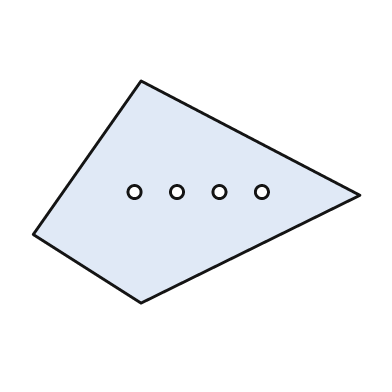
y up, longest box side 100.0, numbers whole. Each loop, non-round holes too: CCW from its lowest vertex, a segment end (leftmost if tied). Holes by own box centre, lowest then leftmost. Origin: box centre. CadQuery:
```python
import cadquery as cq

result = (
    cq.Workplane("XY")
    .moveTo(-17.0, -34.0)
    .lineTo(50.0, -1.0)
    .lineTo(-17.0, 34.0)
    .lineTo(-50.0, -13.0)
    .close()
    .moveTo(-19.0, 0.0)
    .circle(2.0)
    .moveTo(-6.0, 0.0)
    .circle(2.0)
    .moveTo(7.0, 0.0)
    .circle(2.0)
    .moveTo(20.0, 0.0)
    .circle(2.0)
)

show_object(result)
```